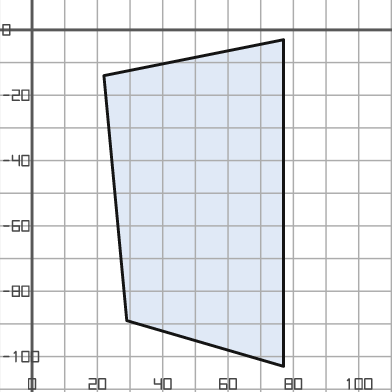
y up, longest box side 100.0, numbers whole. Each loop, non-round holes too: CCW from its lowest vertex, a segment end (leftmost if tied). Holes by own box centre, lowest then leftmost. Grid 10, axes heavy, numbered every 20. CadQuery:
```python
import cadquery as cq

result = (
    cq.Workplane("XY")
    .moveTo(77.0, -103.0)
    .lineTo(77.0, -3.0)
    .lineTo(22.0, -14.0)
    .lineTo(29.0, -89.0)
    .close()
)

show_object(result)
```